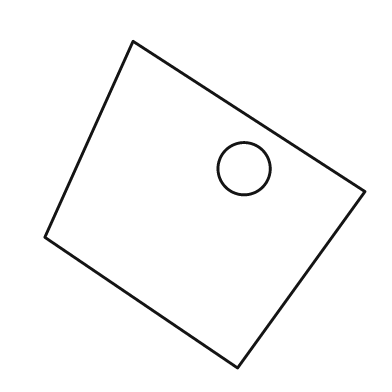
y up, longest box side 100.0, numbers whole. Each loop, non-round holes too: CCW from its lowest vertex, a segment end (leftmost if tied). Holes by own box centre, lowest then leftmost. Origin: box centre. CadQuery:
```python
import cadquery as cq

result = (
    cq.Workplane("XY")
    .moveTo(10.0, -50.0)
    .lineTo(49.0, 4.0)
    .lineTo(-22.0, 50.0)
    .lineTo(-49.0, -10.0)
    .close()
    .moveTo(12.0, 11.0)
    .circle(8.0)
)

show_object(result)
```